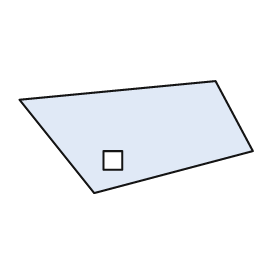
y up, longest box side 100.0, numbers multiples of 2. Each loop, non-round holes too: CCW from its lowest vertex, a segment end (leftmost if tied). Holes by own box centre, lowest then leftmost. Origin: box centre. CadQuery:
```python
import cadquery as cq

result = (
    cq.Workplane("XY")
    .moveTo(-18.0, -24.0)
    .lineTo(50.0, -6.0)
    .lineTo(34.0, 24.0)
    .lineTo(-50.0, 16.0)
    .close()
    .moveTo(-14.0, -14.0)
    .lineTo(-6.0, -14.0)
    .lineTo(-6.0, -6.0)
    .lineTo(-14.0, -6.0)
    .close()
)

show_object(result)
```